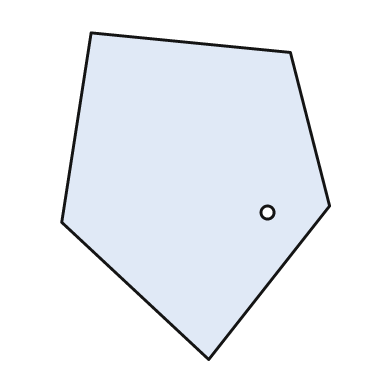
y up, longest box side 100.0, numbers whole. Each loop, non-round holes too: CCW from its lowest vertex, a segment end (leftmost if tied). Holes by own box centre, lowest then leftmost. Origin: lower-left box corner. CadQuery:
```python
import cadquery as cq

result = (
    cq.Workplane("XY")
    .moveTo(45.0, 0.0)
    .lineTo(82.0, 47.0)
    .lineTo(70.0, 94.0)
    .lineTo(9.0, 100.0)
    .lineTo(0.0, 42.0)
    .close()
    .moveTo(63.0, 45.0)
    .circle(2.0)
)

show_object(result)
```